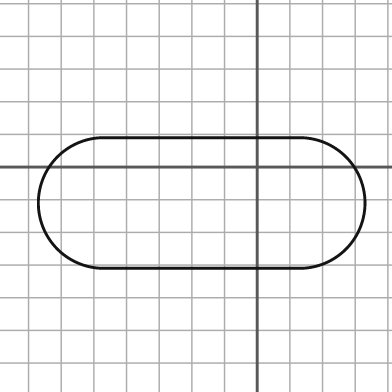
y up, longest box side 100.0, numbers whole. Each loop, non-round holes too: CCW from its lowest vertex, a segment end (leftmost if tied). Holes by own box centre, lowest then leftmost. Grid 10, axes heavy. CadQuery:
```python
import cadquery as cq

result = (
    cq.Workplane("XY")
    .moveTo(-47.0, -31.0)
    .lineTo(13.0, -31.0)
    .threePointArc((33.0, -11.0), (13.0, 9.0))
    .lineTo(-47.0, 9.0)
    .threePointArc((-67.0, -11.0), (-47.0, -31.0))
    .close()
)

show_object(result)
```